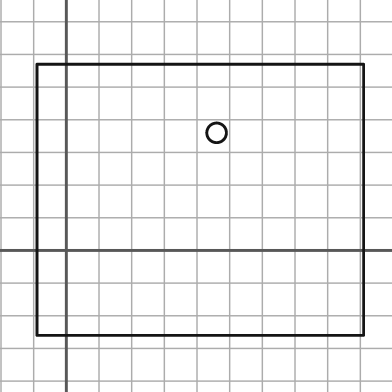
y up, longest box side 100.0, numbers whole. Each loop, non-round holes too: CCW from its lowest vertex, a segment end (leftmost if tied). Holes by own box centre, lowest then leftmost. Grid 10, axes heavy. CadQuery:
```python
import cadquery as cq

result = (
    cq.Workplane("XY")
    .moveTo(-9.0, -26.0)
    .lineTo(91.0, -26.0)
    .lineTo(91.0, 57.0)
    .lineTo(-9.0, 57.0)
    .close()
    .moveTo(46.0, 36.0)
    .circle(3.0)
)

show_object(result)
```